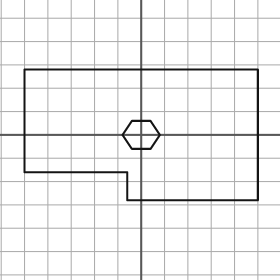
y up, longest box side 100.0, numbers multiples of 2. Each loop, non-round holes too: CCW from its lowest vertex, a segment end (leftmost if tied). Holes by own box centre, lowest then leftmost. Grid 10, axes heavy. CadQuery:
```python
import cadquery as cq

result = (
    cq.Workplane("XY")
    .moveTo(-6.0, -28.0)
    .lineTo(50.0, -28.0)
    .lineTo(50.0, 28.0)
    .lineTo(-50.0, 28.0)
    .lineTo(-50.0, -16.0)
    .lineTo(-6.0, -16.0)
    .close()
    .moveTo(-4.0, -6.0)
    .lineTo(4.0, -6.0)
    .lineTo(8.0, 0.0)
    .lineTo(4.0, 6.0)
    .lineTo(-4.0, 6.0)
    .lineTo(-8.0, 0.0)
    .close()
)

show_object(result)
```